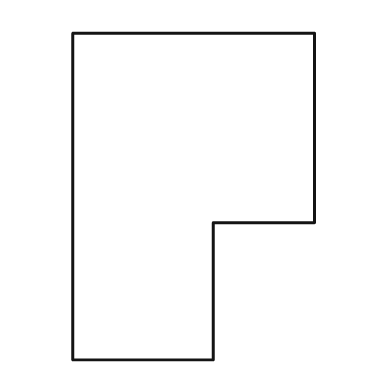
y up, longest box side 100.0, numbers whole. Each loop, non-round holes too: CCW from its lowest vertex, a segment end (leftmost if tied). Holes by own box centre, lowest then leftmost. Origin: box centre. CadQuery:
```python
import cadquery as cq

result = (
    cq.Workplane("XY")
    .moveTo(-37.0, -50.0)
    .lineTo(6.0, -50.0)
    .lineTo(6.0, -8.0)
    .lineTo(37.0, -8.0)
    .lineTo(37.0, 50.0)
    .lineTo(-37.0, 50.0)
    .close()
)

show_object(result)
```